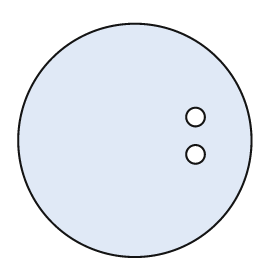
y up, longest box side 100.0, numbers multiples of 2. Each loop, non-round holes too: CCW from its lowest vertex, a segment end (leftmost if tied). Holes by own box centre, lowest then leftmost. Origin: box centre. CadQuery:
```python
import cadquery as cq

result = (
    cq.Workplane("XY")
    .moveTo(0.0, 0.0)
    .circle(50.0)
    .moveTo(26.0, -6.0)
    .circle(4.0)
    .moveTo(26.0, 10.0)
    .circle(4.0)
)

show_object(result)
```